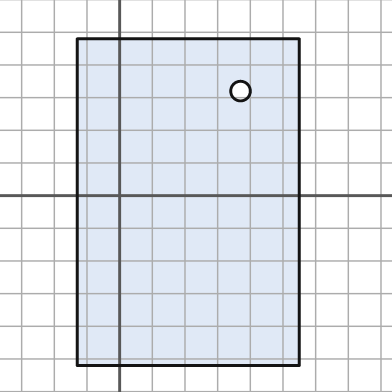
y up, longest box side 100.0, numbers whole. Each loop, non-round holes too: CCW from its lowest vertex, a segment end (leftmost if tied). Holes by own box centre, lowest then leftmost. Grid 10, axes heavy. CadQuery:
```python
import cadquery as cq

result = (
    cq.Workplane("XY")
    .moveTo(-13.0, -52.0)
    .lineTo(55.0, -52.0)
    .lineTo(55.0, 48.0)
    .lineTo(-13.0, 48.0)
    .close()
    .moveTo(37.0, 32.0)
    .circle(3.0)
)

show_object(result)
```